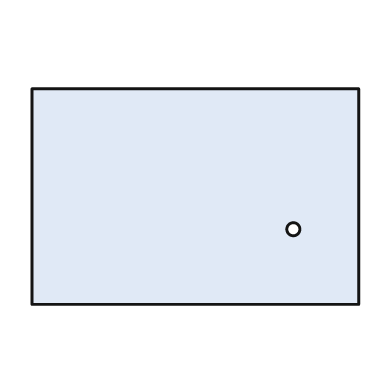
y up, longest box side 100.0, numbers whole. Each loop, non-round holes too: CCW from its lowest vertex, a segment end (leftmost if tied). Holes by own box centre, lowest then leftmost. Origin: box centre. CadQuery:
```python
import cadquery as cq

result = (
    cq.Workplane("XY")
    .moveTo(-50.0, -33.0)
    .lineTo(50.0, -33.0)
    .lineTo(50.0, 33.0)
    .lineTo(-50.0, 33.0)
    .close()
    .moveTo(30.0, -10.0)
    .circle(2.0)
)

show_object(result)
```